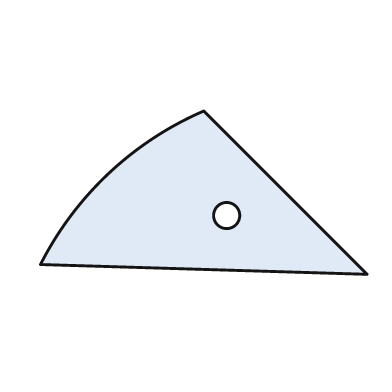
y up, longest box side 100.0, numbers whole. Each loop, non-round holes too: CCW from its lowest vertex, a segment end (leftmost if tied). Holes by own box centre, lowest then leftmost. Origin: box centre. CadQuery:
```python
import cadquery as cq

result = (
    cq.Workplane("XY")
    .moveTo(50.0, -25.0)
    .lineTo(0.0, 25.0)
    .threePointArc((-29.0, 6.0), (-50.0, -22.0))
    .close()
    .moveTo(7.0, -7.0)
    .circle(4.0)
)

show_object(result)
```